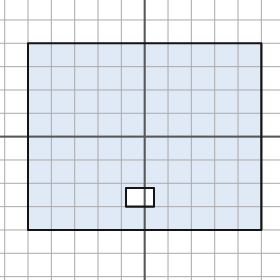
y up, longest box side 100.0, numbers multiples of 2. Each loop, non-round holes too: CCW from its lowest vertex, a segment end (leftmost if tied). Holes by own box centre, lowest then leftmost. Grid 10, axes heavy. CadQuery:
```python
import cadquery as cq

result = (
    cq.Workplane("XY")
    .moveTo(-50.0, -40.0)
    .lineTo(50.0, -40.0)
    .lineTo(50.0, 40.0)
    .lineTo(-50.0, 40.0)
    .close()
    .moveTo(-8.0, -30.0)
    .lineTo(4.0, -30.0)
    .lineTo(4.0, -22.0)
    .lineTo(-8.0, -22.0)
    .close()
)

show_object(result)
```